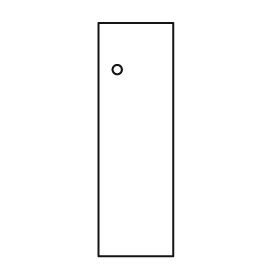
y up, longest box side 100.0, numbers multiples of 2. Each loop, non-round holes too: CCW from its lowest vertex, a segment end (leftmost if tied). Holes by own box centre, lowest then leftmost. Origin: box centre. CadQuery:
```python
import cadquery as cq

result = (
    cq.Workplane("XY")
    .moveTo(-16.0, -50.0)
    .lineTo(16.0, -50.0)
    .lineTo(16.0, 50.0)
    .lineTo(-16.0, 50.0)
    .close()
    .moveTo(-8.0, 30.0)
    .circle(2.0)
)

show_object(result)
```